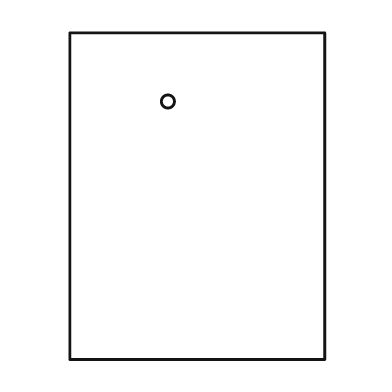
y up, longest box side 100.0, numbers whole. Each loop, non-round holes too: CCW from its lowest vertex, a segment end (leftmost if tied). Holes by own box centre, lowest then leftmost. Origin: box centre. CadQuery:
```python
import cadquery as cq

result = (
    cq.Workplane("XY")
    .moveTo(-39.0, -50.0)
    .lineTo(39.0, -50.0)
    .lineTo(39.0, 50.0)
    .lineTo(-39.0, 50.0)
    .close()
    .moveTo(-9.0, 29.0)
    .circle(2.0)
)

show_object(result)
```